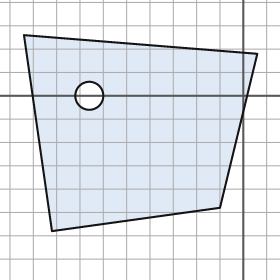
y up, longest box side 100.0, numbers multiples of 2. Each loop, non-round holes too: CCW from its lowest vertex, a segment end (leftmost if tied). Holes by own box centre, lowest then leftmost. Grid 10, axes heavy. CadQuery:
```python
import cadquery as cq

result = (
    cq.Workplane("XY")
    .moveTo(-82.0, -58.0)
    .lineTo(-10.0, -48.0)
    .lineTo(6.0, 18.0)
    .lineTo(-94.0, 26.0)
    .close()
    .moveTo(-66.0, 0.0)
    .circle(6.0)
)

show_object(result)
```